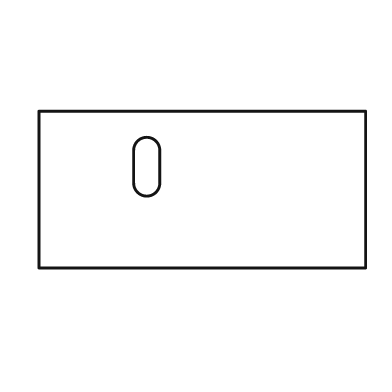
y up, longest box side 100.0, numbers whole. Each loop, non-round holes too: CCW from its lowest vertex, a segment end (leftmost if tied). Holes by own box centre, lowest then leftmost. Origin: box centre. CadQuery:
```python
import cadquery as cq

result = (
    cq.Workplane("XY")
    .moveTo(-50.0, -24.0)
    .lineTo(50.0, -24.0)
    .lineTo(50.0, 24.0)
    .lineTo(-50.0, 24.0)
    .close()
    .moveTo(-21.0, 2.0)
    .threePointArc((-17.0, -2.0), (-13.0, 2.0))
    .lineTo(-13.0, 12.0)
    .threePointArc((-17.0, 16.0), (-21.0, 12.0))
    .close()
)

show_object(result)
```